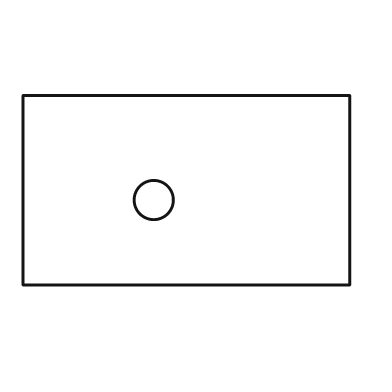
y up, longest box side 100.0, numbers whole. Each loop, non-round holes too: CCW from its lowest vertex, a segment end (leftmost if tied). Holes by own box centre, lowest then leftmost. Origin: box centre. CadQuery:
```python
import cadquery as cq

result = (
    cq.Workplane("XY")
    .moveTo(-50.0, -29.0)
    .lineTo(50.0, -29.0)
    .lineTo(50.0, 29.0)
    .lineTo(-50.0, 29.0)
    .close()
    .moveTo(-10.0, -3.0)
    .circle(6.0)
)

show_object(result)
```